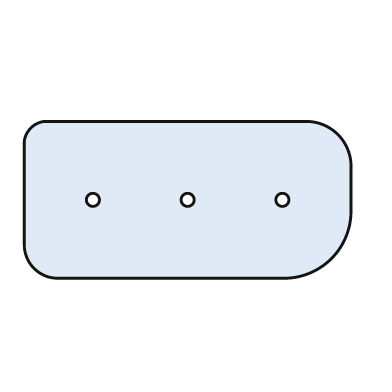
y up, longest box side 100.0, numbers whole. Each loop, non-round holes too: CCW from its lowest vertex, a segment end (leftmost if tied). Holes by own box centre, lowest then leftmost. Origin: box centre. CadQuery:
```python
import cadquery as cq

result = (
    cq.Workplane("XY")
    .moveTo(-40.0, -24.0)
    .lineTo(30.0, -24.0)
    .threePointArc((44.0, -18.0), (50.0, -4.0))
    .lineTo(50.0, 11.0)
    .threePointArc((46.0, 20.0), (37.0, 24.0))
    .lineTo(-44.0, 24.0)
    .threePointArc((-48.0, 22.0), (-50.0, 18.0))
    .lineTo(-50.0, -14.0)
    .threePointArc((-47.0, -21.0), (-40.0, -24.0))
    .close()
    .moveTo(-29.0, 0.0)
    .circle(2.0)
    .moveTo(0.0, 0.0)
    .circle(2.0)
    .moveTo(29.0, 0.0)
    .circle(2.0)
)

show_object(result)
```